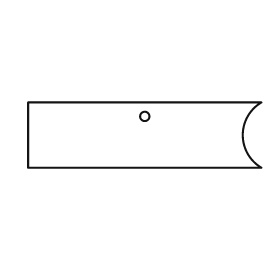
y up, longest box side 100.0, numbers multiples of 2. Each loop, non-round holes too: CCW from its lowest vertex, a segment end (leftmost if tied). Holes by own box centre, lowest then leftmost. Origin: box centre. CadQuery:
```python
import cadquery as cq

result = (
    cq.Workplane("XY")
    .moveTo(-50.0, -14.0)
    .lineTo(50.0, -14.0)
    .threePointArc((42.0, 0.0), (50.0, 14.0))
    .lineTo(-50.0, 14.0)
    .close()
    .moveTo(0.0, 8.0)
    .circle(2.0)
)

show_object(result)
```